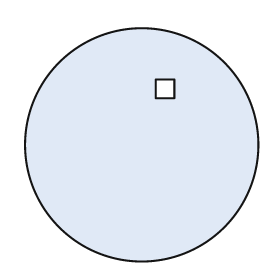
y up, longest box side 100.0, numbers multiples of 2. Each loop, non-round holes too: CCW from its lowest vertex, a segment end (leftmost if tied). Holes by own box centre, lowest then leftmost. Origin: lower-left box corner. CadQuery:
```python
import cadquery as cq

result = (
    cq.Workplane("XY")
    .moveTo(50.0, 50.0)
    .circle(50.0)
    .moveTo(56.0, 70.0)
    .lineTo(64.0, 70.0)
    .lineTo(64.0, 78.0)
    .lineTo(56.0, 78.0)
    .close()
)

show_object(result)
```